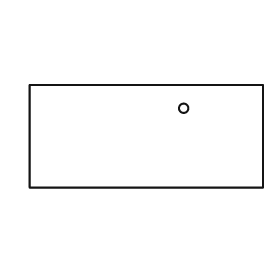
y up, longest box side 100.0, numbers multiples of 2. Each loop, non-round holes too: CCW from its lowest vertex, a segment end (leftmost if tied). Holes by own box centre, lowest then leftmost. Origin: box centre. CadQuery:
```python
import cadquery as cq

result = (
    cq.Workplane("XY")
    .moveTo(-50.0, -22.0)
    .lineTo(50.0, -22.0)
    .lineTo(50.0, 22.0)
    .lineTo(-50.0, 22.0)
    .close()
    .moveTo(16.0, 12.0)
    .circle(2.0)
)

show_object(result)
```